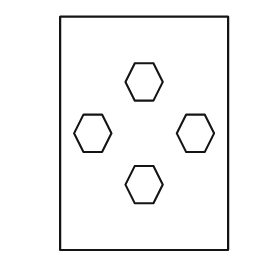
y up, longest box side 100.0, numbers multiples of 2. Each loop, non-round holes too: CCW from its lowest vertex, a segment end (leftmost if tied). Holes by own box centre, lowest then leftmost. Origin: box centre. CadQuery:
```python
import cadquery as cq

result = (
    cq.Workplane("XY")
    .moveTo(-36.0, -50.0)
    .lineTo(36.0, -50.0)
    .lineTo(36.0, 50.0)
    .lineTo(-36.0, 50.0)
    .close()
    .moveTo(-4.0, -30.0)
    .lineTo(4.0, -30.0)
    .lineTo(8.0, -22.0)
    .lineTo(4.0, -14.0)
    .lineTo(-4.0, -14.0)
    .lineTo(-8.0, -22.0)
    .close()
    .moveTo(-26.0, -8.0)
    .lineTo(-18.0, -8.0)
    .lineTo(-14.0, 0.0)
    .lineTo(-18.0, 8.0)
    .lineTo(-26.0, 8.0)
    .lineTo(-30.0, 0.0)
    .close()
    .moveTo(18.0, -8.0)
    .lineTo(26.0, -8.0)
    .lineTo(30.0, 0.0)
    .lineTo(26.0, 8.0)
    .lineTo(18.0, 8.0)
    .lineTo(14.0, 0.0)
    .close()
    .moveTo(-4.0, 14.0)
    .lineTo(4.0, 14.0)
    .lineTo(8.0, 22.0)
    .lineTo(4.0, 30.0)
    .lineTo(-4.0, 30.0)
    .lineTo(-8.0, 22.0)
    .close()
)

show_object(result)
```